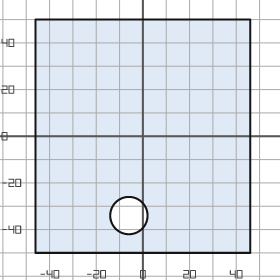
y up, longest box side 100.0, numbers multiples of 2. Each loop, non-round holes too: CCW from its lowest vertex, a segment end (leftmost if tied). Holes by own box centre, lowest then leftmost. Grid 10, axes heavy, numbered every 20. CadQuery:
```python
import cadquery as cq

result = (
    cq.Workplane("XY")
    .moveTo(-46.0, -50.0)
    .lineTo(46.0, -50.0)
    .lineTo(46.0, 50.0)
    .lineTo(-46.0, 50.0)
    .close()
    .moveTo(-6.0, -34.0)
    .circle(8.0)
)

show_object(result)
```